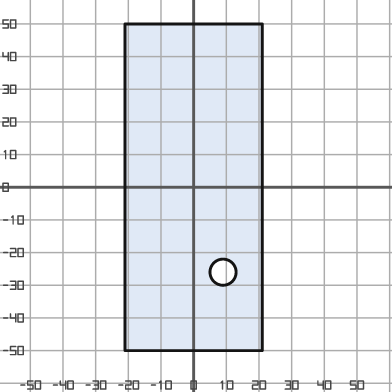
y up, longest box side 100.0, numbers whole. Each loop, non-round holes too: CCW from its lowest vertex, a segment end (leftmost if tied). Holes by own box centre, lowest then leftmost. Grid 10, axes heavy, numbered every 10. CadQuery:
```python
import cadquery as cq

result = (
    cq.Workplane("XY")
    .moveTo(-21.0, -50.0)
    .lineTo(21.0, -50.0)
    .lineTo(21.0, 50.0)
    .lineTo(-21.0, 50.0)
    .close()
    .moveTo(9.0, -26.0)
    .circle(4.0)
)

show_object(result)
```